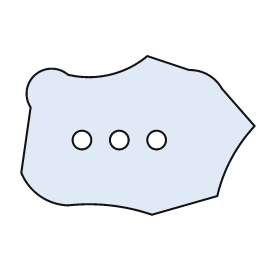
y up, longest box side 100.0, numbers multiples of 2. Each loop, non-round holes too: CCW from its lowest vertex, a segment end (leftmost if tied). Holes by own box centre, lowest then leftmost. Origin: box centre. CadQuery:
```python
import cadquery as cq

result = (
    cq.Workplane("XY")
    .moveTo(6.0, -34.0)
    .lineTo(34.0, -26.0)
    .threePointArc((40.0, -10.0), (50.0, 4.0))
    .lineTo(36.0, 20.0)
    .threePointArc((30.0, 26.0), (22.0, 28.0))
    .lineTo(4.0, 34.0)
    .threePointArc((-12.0, 26.0), (-30.0, 26.0))
    .threePointArc((-44.0, 26.0), (-46.0, 12.0))
    .lineTo(-50.0, -16.0)
    .threePointArc((-42.0, -26.0), (-30.0, -30.0))
    .threePointArc((-12.0, -30.0), (6.0, -34.0))
    .close()
    .moveTo(-24.0, -2.0)
    .circle(4.0)
    .moveTo(-8.0, -2.0)
    .circle(4.0)
    .moveTo(8.0, -2.0)
    .circle(4.0)
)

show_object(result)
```